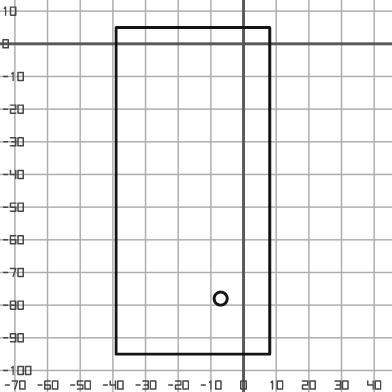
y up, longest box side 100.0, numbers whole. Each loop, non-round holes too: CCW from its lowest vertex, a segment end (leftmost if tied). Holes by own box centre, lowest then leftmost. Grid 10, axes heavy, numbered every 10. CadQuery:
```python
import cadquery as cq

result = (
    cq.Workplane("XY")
    .moveTo(-39.0, -95.0)
    .lineTo(8.0, -95.0)
    .lineTo(8.0, 5.0)
    .lineTo(-39.0, 5.0)
    .close()
    .moveTo(-7.0, -78.0)
    .circle(2.0)
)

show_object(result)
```